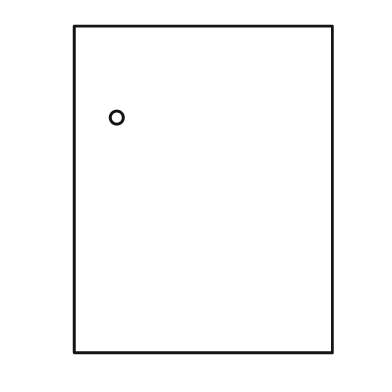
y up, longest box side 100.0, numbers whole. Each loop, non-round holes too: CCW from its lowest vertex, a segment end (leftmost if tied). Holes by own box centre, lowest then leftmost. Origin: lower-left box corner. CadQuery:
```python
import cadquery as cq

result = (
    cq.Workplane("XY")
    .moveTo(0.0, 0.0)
    .lineTo(79.0, 0.0)
    .lineTo(79.0, 100.0)
    .lineTo(0.0, 100.0)
    .close()
    .moveTo(13.0, 72.0)
    .circle(2.0)
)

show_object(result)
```